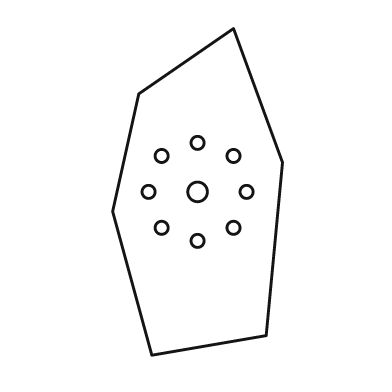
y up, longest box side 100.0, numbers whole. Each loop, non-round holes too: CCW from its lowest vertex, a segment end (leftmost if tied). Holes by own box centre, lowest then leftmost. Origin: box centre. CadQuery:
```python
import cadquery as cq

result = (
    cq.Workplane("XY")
    .moveTo(-14.0, -50.0)
    .lineTo(21.0, -44.0)
    .lineTo(26.0, 9.0)
    .lineTo(11.0, 50.0)
    .lineTo(-18.0, 30.0)
    .lineTo(-26.0, -6.0)
    .close()
    .moveTo(0.0, -15.0)
    .circle(2.0)
    .moveTo(-11.0, -11.0)
    .circle(2.0)
    .moveTo(11.0, -11.0)
    .circle(2.0)
    .moveTo(-15.0, 0.0)
    .circle(2.0)
    .moveTo(0.0, 0.0)
    .circle(3.0)
    .moveTo(15.0, 0.0)
    .circle(2.0)
    .moveTo(-11.0, 11.0)
    .circle(2.0)
    .moveTo(11.0, 11.0)
    .circle(2.0)
    .moveTo(0.0, 15.0)
    .circle(2.0)
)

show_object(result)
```